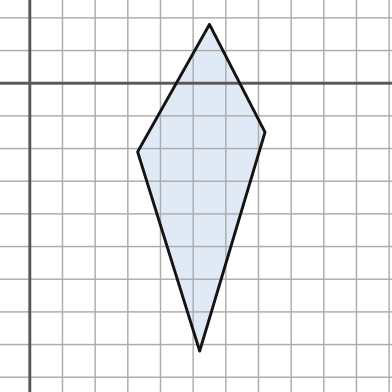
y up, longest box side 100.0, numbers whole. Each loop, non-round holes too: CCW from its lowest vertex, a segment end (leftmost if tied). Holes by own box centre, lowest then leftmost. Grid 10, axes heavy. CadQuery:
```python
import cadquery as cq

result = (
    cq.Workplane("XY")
    .moveTo(52.0, -82.0)
    .lineTo(72.0, -15.0)
    .lineTo(55.0, 18.0)
    .lineTo(33.0, -21.0)
    .close()
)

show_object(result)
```